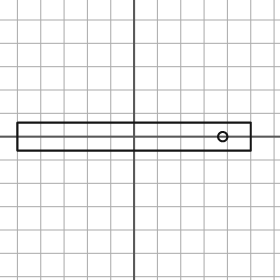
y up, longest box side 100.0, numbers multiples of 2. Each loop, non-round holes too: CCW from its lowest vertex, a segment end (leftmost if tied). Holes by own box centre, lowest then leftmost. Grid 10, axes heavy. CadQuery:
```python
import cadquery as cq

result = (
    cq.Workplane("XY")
    .moveTo(-50.0, -6.0)
    .lineTo(50.0, -6.0)
    .lineTo(50.0, 6.0)
    .lineTo(-50.0, 6.0)
    .close()
    .moveTo(38.0, 0.0)
    .circle(2.0)
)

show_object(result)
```